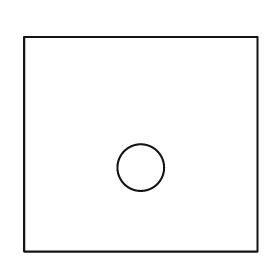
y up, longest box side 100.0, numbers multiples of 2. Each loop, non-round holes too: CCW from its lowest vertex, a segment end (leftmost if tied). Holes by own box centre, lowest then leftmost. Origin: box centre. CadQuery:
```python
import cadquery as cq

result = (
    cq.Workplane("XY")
    .moveTo(-50.0, -46.0)
    .lineTo(50.0, -46.0)
    .lineTo(50.0, 46.0)
    .lineTo(-50.0, 46.0)
    .close()
    .moveTo(0.0, -10.0)
    .circle(10.0)
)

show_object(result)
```